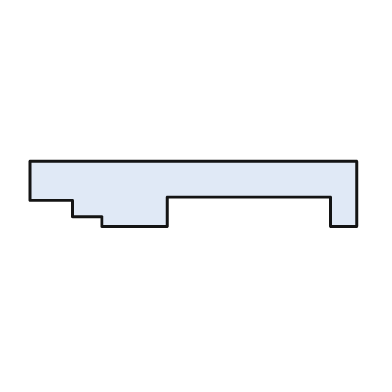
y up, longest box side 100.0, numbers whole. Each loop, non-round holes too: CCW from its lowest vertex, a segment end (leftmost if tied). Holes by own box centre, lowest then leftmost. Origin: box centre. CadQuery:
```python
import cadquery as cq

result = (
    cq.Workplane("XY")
    .moveTo(-28.0, -10.0)
    .lineTo(-8.0, -10.0)
    .lineTo(-8.0, -1.0)
    .lineTo(42.0, -1.0)
    .lineTo(42.0, -10.0)
    .lineTo(50.0, -10.0)
    .lineTo(50.0, 10.0)
    .lineTo(-50.0, 10.0)
    .lineTo(-50.0, -2.0)
    .lineTo(-37.0, -2.0)
    .lineTo(-37.0, -7.0)
    .lineTo(-28.0, -7.0)
    .close()
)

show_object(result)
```